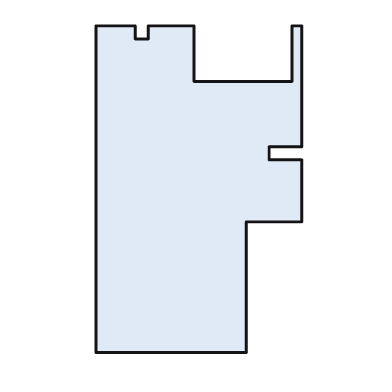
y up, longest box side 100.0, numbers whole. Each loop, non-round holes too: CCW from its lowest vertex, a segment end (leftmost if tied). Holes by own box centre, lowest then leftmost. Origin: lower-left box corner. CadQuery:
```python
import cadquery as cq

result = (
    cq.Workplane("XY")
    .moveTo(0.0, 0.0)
    .lineTo(46.0, 0.0)
    .lineTo(46.0, 40.0)
    .lineTo(63.0, 40.0)
    .lineTo(63.0, 59.0)
    .lineTo(53.0, 59.0)
    .lineTo(53.0, 63.0)
    .lineTo(63.0, 63.0)
    .lineTo(63.0, 100.0)
    .lineTo(60.0, 100.0)
    .lineTo(60.0, 83.0)
    .lineTo(30.0, 83.0)
    .lineTo(30.0, 100.0)
    .lineTo(16.0, 100.0)
    .lineTo(16.0, 96.0)
    .lineTo(12.0, 96.0)
    .lineTo(12.0, 100.0)
    .lineTo(0.0, 100.0)
    .close()
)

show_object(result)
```